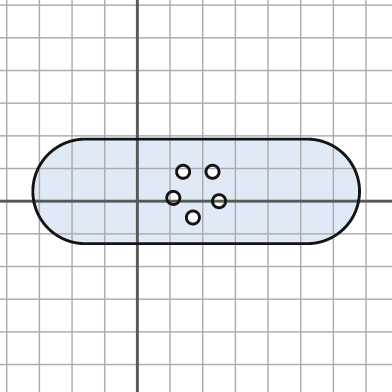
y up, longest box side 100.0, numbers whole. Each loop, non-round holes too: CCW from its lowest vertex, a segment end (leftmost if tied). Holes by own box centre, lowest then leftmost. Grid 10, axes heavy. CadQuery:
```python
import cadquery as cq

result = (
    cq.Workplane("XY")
    .moveTo(-16.0, -13.0)
    .lineTo(52.0, -13.0)
    .threePointArc((68.0, 3.0), (52.0, 19.0))
    .lineTo(-16.0, 19.0)
    .threePointArc((-32.0, 3.0), (-16.0, -13.0))
    .close()
    .moveTo(17.0, -5.0)
    .circle(2.0)
    .moveTo(25.0, 0.0)
    .circle(2.0)
    .moveTo(11.0, 1.0)
    .circle(2.0)
    .moveTo(14.0, 9.0)
    .circle(2.0)
    .moveTo(23.0, 9.0)
    .circle(2.0)
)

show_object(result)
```